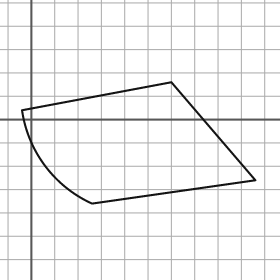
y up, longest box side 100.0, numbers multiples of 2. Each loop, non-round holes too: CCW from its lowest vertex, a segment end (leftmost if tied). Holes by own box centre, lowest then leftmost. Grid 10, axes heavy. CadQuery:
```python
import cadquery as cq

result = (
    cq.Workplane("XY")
    .moveTo(26.0, -36.0)
    .lineTo(96.0, -26.0)
    .lineTo(60.0, 16.0)
    .lineTo(-4.0, 4.0)
    .threePointArc((6.0, -20.0), (26.0, -36.0))
    .close()
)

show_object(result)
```